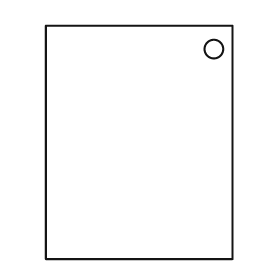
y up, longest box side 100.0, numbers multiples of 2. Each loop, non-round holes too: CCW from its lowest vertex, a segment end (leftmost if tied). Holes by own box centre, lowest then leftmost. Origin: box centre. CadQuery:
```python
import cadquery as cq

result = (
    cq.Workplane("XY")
    .moveTo(-40.0, -50.0)
    .lineTo(40.0, -50.0)
    .lineTo(40.0, 50.0)
    .lineTo(-40.0, 50.0)
    .close()
    .moveTo(32.0, 40.0)
    .circle(4.0)
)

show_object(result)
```